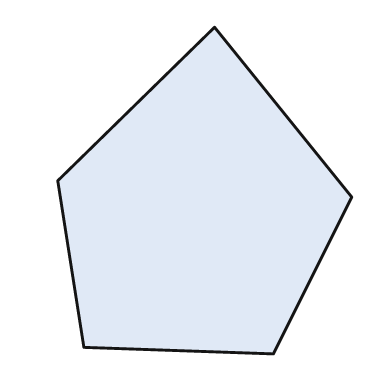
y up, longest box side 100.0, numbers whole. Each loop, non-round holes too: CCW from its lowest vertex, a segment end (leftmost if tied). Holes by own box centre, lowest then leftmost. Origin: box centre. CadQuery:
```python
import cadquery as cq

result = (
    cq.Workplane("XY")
    .moveTo(21.0, -50.0)
    .lineTo(45.0, -2.0)
    .lineTo(3.0, 50.0)
    .lineTo(-45.0, 3.0)
    .lineTo(-37.0, -48.0)
    .close()
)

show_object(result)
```